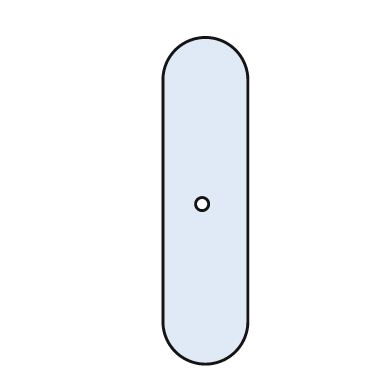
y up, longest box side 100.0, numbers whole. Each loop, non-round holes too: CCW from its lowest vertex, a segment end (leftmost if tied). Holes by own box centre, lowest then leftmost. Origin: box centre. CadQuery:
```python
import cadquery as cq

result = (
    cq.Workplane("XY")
    .moveTo(-13.0, -37.0)
    .threePointArc((0.0, -50.0), (13.0, -37.0))
    .lineTo(13.0, 37.0)
    .threePointArc((0.0, 50.0), (-13.0, 37.0))
    .close()
    .moveTo(-1.0, -1.0)
    .circle(2.0)
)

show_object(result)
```